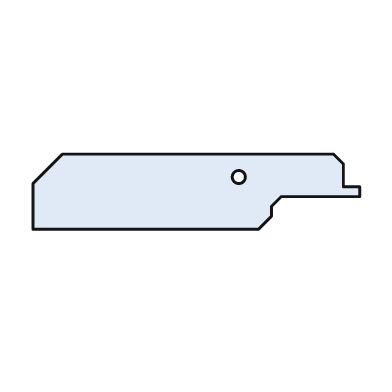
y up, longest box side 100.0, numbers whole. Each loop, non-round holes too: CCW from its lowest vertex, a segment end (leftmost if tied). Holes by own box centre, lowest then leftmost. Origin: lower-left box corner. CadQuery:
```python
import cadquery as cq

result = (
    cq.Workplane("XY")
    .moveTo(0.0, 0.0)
    .lineTo(69.0, 0.0)
    .lineTo(73.0, 4.0)
    .lineTo(73.0, 7.0)
    .lineTo(76.0, 10.0)
    .lineTo(100.0, 10.0)
    .lineTo(100.0, 13.0)
    .lineTo(95.0, 13.0)
    .lineTo(95.0, 20.0)
    .lineTo(92.0, 23.0)
    .lineTo(9.0, 23.0)
    .lineTo(0.0, 14.0)
    .close()
    .moveTo(63.0, 16.0)
    .circle(2.0)
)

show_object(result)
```